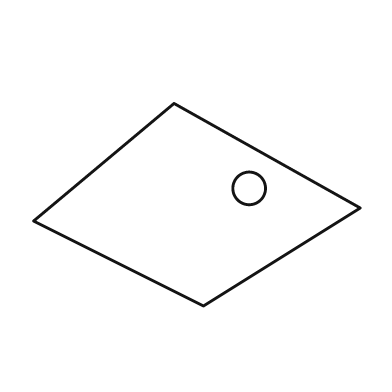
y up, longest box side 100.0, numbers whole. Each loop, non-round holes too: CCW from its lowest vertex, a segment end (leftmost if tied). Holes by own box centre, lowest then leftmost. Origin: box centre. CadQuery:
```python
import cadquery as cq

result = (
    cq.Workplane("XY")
    .moveTo(2.0, -31.0)
    .lineTo(50.0, -1.0)
    .lineTo(-7.0, 31.0)
    .lineTo(-50.0, -5.0)
    .close()
    .moveTo(16.0, 5.0)
    .circle(5.0)
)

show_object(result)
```